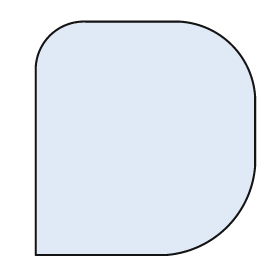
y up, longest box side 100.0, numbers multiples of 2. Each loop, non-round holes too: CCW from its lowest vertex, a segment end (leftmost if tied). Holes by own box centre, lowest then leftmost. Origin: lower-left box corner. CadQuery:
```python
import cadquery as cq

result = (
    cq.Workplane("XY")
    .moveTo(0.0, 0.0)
    .lineTo(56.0, 0.0)
    .threePointArc((82.0, 12.0), (94.0, 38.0))
    .lineTo(94.0, 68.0)
    .threePointArc((84.0, 90.0), (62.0, 100.0))
    .lineTo(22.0, 100.0)
    .threePointArc((6.0, 94.0), (0.0, 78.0))
    .close()
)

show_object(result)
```